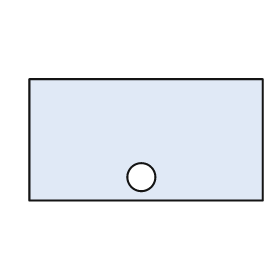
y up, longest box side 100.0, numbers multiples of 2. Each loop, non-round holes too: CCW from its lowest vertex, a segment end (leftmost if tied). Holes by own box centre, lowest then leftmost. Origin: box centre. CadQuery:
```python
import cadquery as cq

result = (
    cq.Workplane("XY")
    .moveTo(-50.0, -26.0)
    .lineTo(50.0, -26.0)
    .lineTo(50.0, 26.0)
    .lineTo(-50.0, 26.0)
    .close()
    .moveTo(-2.0, -16.0)
    .circle(6.0)
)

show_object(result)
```